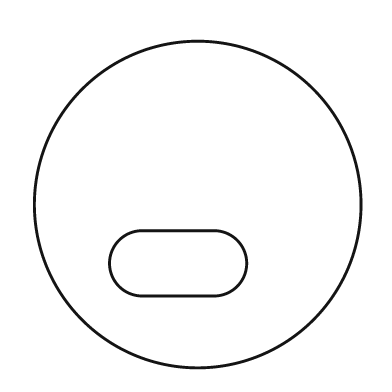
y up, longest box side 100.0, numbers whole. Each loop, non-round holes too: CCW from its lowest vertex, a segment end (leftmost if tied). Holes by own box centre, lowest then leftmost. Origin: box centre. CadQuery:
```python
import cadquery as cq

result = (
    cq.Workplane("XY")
    .moveTo(0.0, 0.0)
    .circle(50.0)
    .moveTo(-17.0, -28.0)
    .lineTo(5.0, -28.0)
    .threePointArc((15.0, -18.0), (5.0, -8.0))
    .lineTo(-17.0, -8.0)
    .threePointArc((-27.0, -18.0), (-17.0, -28.0))
    .close()
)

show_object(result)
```